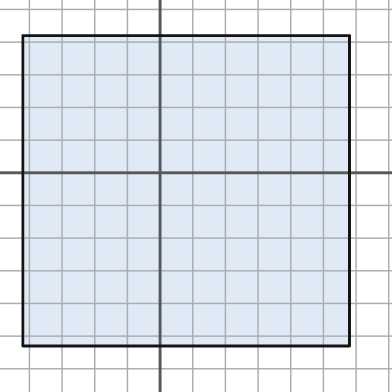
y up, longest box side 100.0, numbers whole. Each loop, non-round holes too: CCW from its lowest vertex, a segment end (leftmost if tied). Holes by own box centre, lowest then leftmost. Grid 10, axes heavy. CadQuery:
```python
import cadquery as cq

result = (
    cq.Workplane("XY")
    .moveTo(-42.0, -53.0)
    .lineTo(58.0, -53.0)
    .lineTo(58.0, 42.0)
    .lineTo(-42.0, 42.0)
    .close()
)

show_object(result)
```